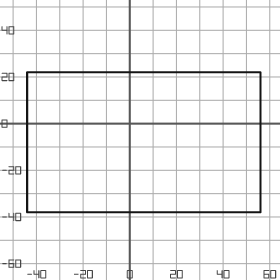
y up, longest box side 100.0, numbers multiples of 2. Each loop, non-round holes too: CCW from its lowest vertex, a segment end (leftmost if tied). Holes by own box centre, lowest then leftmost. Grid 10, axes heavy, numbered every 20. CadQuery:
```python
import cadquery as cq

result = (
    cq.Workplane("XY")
    .moveTo(-44.0, -38.0)
    .lineTo(56.0, -38.0)
    .lineTo(56.0, 22.0)
    .lineTo(-44.0, 22.0)
    .close()
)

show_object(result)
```